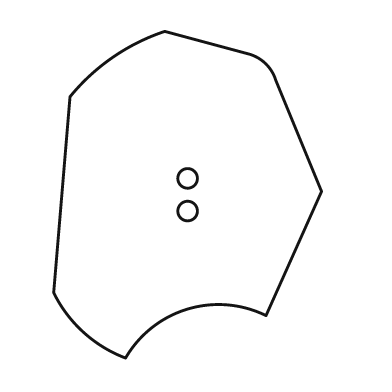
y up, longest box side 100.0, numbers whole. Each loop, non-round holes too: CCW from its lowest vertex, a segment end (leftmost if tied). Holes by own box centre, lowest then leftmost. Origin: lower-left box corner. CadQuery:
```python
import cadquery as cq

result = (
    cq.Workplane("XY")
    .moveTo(22.0, 0.0)
    .threePointArc((41.0, 15.0), (65.0, 13.0))
    .lineTo(82.0, 51.0)
    .lineTo(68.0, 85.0)
    .threePointArc((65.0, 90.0), (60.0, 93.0))
    .lineTo(34.0, 100.0)
    .threePointArc((18.0, 92.0), (5.0, 80.0))
    .lineTo(0.0, 20.0)
    .threePointArc((9.0, 8.0), (22.0, 0.0))
    .close()
    .moveTo(41.0, 45.0)
    .circle(3.0)
    .moveTo(41.0, 55.0)
    .circle(3.0)
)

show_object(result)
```